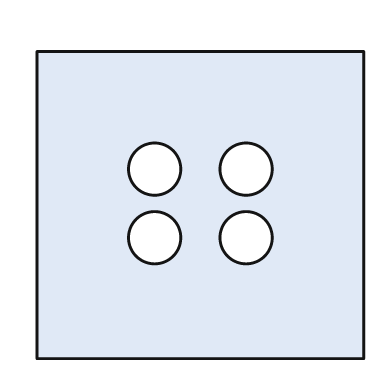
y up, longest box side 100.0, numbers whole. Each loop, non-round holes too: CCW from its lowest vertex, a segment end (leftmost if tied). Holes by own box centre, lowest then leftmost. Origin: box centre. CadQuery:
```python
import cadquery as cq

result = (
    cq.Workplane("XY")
    .moveTo(-50.0, -47.0)
    .lineTo(50.0, -47.0)
    .lineTo(50.0, 47.0)
    .lineTo(-50.0, 47.0)
    .close()
    .moveTo(-14.0, -10.0)
    .circle(8.0)
    .moveTo(14.0, -10.0)
    .circle(8.0)
    .moveTo(-14.0, 11.0)
    .circle(8.0)
    .moveTo(14.0, 11.0)
    .circle(8.0)
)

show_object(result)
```